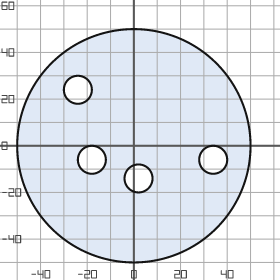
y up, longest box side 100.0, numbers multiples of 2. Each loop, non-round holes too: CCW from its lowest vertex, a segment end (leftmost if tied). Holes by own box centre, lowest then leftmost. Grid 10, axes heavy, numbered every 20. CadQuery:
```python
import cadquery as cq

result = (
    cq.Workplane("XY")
    .moveTo(0.0, 0.0)
    .circle(50.0)
    .moveTo(2.0, -14.0)
    .circle(6.0)
    .moveTo(-18.0, -6.0)
    .circle(6.0)
    .moveTo(34.0, -6.0)
    .circle(6.0)
    .moveTo(-24.0, 24.0)
    .circle(6.0)
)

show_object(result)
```